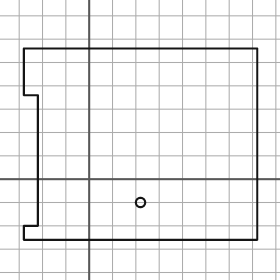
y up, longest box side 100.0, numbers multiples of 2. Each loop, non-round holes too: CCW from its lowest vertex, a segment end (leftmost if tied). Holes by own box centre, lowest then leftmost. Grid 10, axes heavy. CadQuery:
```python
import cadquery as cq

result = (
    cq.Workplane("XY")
    .moveTo(-28.0, -26.0)
    .lineTo(72.0, -26.0)
    .lineTo(72.0, 56.0)
    .lineTo(-28.0, 56.0)
    .lineTo(-28.0, 36.0)
    .lineTo(-22.0, 36.0)
    .lineTo(-22.0, -20.0)
    .lineTo(-28.0, -20.0)
    .close()
    .moveTo(22.0, -10.0)
    .circle(2.0)
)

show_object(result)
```